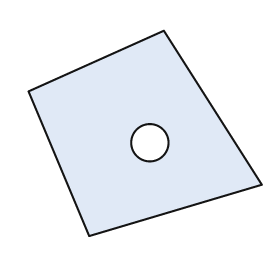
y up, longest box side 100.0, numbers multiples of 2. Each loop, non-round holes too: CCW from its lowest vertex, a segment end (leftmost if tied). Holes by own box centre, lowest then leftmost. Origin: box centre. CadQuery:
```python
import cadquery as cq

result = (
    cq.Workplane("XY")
    .moveTo(-24.0, -44.0)
    .lineTo(50.0, -22.0)
    .lineTo(8.0, 44.0)
    .lineTo(-50.0, 18.0)
    .close()
    .moveTo(2.0, -4.0)
    .circle(8.0)
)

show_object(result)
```